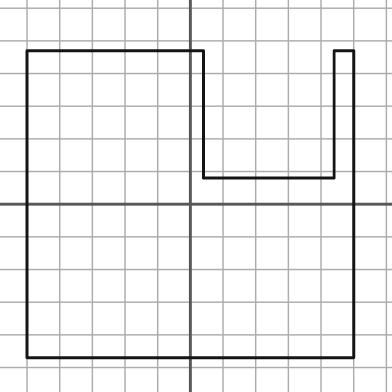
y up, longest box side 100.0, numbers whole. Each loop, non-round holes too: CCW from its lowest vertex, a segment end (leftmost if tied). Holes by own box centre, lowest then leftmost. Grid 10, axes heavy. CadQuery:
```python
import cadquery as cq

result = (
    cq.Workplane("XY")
    .moveTo(-50.0, -47.0)
    .lineTo(50.0, -47.0)
    .lineTo(50.0, 47.0)
    .lineTo(44.0, 47.0)
    .lineTo(44.0, 8.0)
    .lineTo(4.0, 8.0)
    .lineTo(4.0, 47.0)
    .lineTo(-50.0, 47.0)
    .close()
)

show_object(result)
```